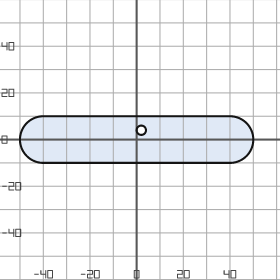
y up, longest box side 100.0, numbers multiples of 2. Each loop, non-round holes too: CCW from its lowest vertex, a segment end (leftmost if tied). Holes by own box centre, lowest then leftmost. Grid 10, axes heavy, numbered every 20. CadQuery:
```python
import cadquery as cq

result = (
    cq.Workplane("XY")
    .moveTo(-40.0, -10.0)
    .lineTo(40.0, -10.0)
    .threePointArc((50.0, 0.0), (40.0, 10.0))
    .lineTo(-40.0, 10.0)
    .threePointArc((-50.0, 0.0), (-40.0, -10.0))
    .close()
    .moveTo(2.0, 4.0)
    .circle(2.0)
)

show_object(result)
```